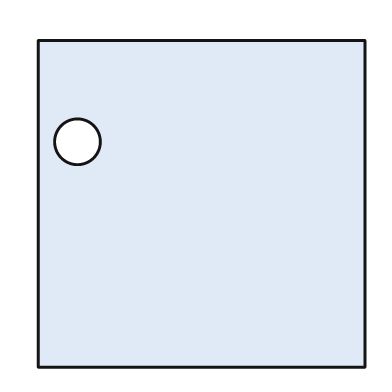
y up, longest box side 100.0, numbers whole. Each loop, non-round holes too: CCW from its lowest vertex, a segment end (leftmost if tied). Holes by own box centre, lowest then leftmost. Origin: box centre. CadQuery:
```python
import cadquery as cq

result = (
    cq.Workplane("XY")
    .moveTo(-50.0, -50.0)
    .lineTo(50.0, -50.0)
    .lineTo(50.0, 50.0)
    .lineTo(-50.0, 50.0)
    .close()
    .moveTo(-38.0, 19.0)
    .circle(7.0)
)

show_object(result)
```